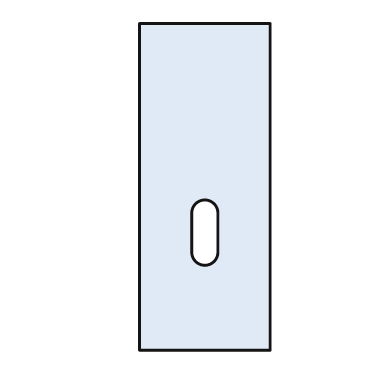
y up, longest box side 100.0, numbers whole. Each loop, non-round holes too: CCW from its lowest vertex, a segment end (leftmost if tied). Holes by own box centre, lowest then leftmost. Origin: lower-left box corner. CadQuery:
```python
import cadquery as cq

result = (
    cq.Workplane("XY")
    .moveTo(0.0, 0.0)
    .lineTo(40.0, 0.0)
    .lineTo(40.0, 100.0)
    .lineTo(0.0, 100.0)
    .close()
    .moveTo(16.0, 30.0)
    .threePointArc((20.0, 26.0), (24.0, 30.0))
    .lineTo(24.0, 42.0)
    .threePointArc((20.0, 46.0), (16.0, 42.0))
    .close()
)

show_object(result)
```